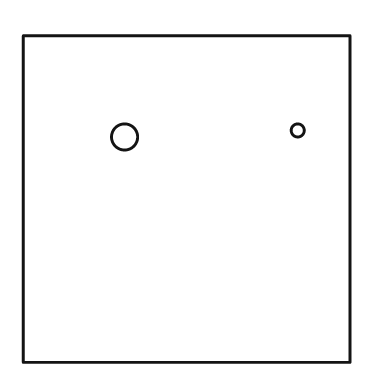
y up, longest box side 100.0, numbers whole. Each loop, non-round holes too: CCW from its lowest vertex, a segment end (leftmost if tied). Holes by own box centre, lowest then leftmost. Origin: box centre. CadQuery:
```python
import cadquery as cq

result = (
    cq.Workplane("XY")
    .moveTo(-50.0, -50.0)
    .lineTo(50.0, -50.0)
    .lineTo(50.0, 50.0)
    .lineTo(-50.0, 50.0)
    .close()
    .moveTo(-19.0, 19.0)
    .circle(4.0)
    .moveTo(34.0, 21.0)
    .circle(2.0)
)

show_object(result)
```